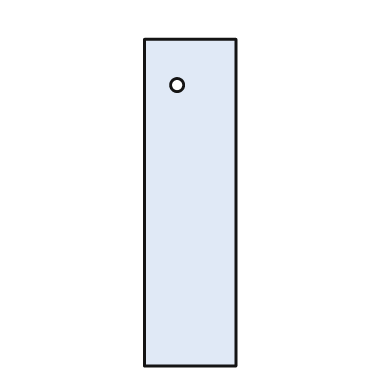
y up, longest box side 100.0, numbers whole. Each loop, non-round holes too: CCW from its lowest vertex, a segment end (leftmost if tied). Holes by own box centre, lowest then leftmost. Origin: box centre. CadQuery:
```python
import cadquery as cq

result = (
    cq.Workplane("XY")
    .moveTo(-14.0, -50.0)
    .lineTo(14.0, -50.0)
    .lineTo(14.0, 50.0)
    .lineTo(-14.0, 50.0)
    .close()
    .moveTo(-4.0, 36.0)
    .circle(2.0)
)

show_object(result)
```